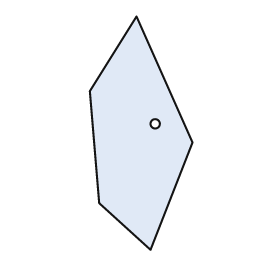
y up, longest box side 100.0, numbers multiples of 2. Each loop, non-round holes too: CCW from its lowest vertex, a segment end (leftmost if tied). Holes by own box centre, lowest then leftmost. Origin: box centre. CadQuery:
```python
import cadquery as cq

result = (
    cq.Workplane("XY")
    .moveTo(4.0, -50.0)
    .lineTo(22.0, -4.0)
    .lineTo(-2.0, 50.0)
    .lineTo(-22.0, 18.0)
    .lineTo(-18.0, -30.0)
    .close()
    .moveTo(6.0, 4.0)
    .circle(2.0)
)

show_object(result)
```